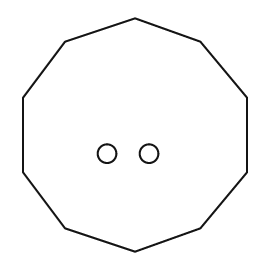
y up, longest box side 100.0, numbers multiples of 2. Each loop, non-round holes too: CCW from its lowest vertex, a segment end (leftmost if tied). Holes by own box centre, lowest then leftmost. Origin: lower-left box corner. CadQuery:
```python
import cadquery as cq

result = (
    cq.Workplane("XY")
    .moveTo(48.0, 0.0)
    .lineTo(76.0, 10.0)
    .lineTo(96.0, 34.0)
    .lineTo(96.0, 66.0)
    .lineTo(76.0, 90.0)
    .lineTo(48.0, 100.0)
    .lineTo(18.0, 90.0)
    .lineTo(0.0, 66.0)
    .lineTo(0.0, 34.0)
    .lineTo(18.0, 10.0)
    .close()
    .moveTo(36.0, 42.0)
    .circle(4.0)
    .moveTo(54.0, 42.0)
    .circle(4.0)
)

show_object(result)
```